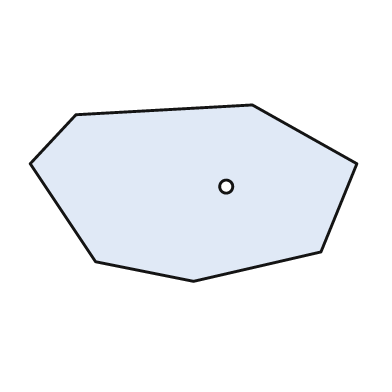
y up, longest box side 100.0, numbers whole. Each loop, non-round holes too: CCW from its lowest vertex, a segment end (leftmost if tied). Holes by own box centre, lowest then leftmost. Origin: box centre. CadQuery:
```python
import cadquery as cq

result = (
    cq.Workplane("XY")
    .moveTo(0.0, -27.0)
    .lineTo(39.0, -18.0)
    .lineTo(50.0, 9.0)
    .lineTo(18.0, 27.0)
    .lineTo(-36.0, 24.0)
    .lineTo(-50.0, 9.0)
    .lineTo(-30.0, -21.0)
    .close()
    .moveTo(10.0, 2.0)
    .circle(2.0)
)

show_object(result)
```